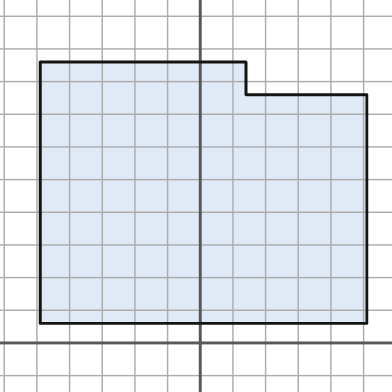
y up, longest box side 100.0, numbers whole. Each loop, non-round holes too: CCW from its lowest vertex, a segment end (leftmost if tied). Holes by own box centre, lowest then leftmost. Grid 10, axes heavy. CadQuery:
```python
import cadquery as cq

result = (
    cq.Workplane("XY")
    .moveTo(-49.0, 6.0)
    .lineTo(51.0, 6.0)
    .lineTo(51.0, 76.0)
    .lineTo(14.0, 76.0)
    .lineTo(14.0, 86.0)
    .lineTo(-49.0, 86.0)
    .close()
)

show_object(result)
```